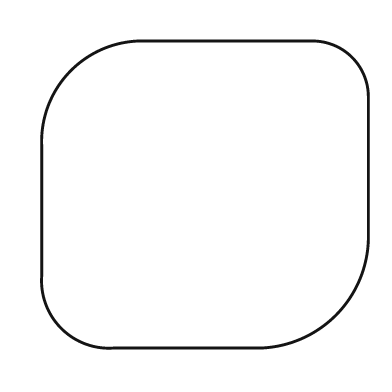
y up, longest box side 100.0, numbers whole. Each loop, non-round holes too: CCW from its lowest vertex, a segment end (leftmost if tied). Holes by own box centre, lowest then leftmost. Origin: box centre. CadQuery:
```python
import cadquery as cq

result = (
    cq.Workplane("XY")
    .moveTo(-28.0, -47.0)
    .lineTo(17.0, -47.0)
    .threePointArc((40.0, -37.0), (50.0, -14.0))
    .lineTo(50.0, 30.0)
    .threePointArc((45.0, 42.0), (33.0, 47.0))
    .lineTo(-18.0, 47.0)
    .threePointArc((-41.0, 38.0), (-50.0, 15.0))
    .lineTo(-50.0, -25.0)
    .threePointArc((-44.0, -41.0), (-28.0, -47.0))
    .close()
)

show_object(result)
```